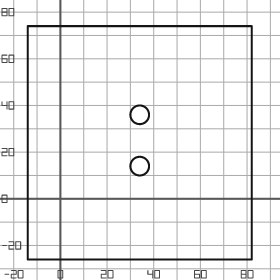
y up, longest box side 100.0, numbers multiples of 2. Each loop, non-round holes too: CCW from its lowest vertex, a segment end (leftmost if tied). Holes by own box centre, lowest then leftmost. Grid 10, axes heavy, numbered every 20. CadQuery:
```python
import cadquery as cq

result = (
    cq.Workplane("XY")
    .moveTo(-14.0, -26.0)
    .lineTo(82.0, -26.0)
    .lineTo(82.0, 74.0)
    .lineTo(-14.0, 74.0)
    .close()
    .moveTo(34.0, 14.0)
    .circle(4.0)
    .moveTo(34.0, 36.0)
    .circle(4.0)
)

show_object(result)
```